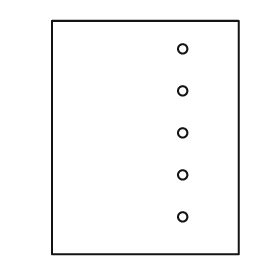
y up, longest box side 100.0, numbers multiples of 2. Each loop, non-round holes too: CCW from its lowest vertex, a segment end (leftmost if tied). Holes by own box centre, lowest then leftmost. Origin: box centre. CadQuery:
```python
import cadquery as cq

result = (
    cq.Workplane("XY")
    .moveTo(-40.0, -50.0)
    .lineTo(40.0, -50.0)
    .lineTo(40.0, 50.0)
    .lineTo(-40.0, 50.0)
    .close()
    .moveTo(16.0, -34.0)
    .circle(2.0)
    .moveTo(16.0, -16.0)
    .circle(2.0)
    .moveTo(16.0, 2.0)
    .circle(2.0)
    .moveTo(16.0, 20.0)
    .circle(2.0)
    .moveTo(16.0, 38.0)
    .circle(2.0)
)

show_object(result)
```